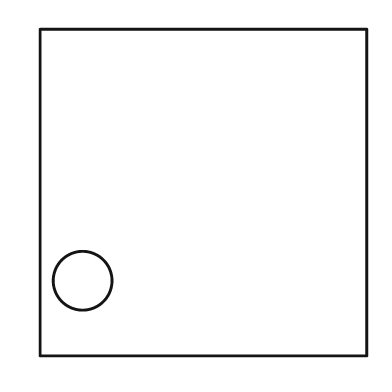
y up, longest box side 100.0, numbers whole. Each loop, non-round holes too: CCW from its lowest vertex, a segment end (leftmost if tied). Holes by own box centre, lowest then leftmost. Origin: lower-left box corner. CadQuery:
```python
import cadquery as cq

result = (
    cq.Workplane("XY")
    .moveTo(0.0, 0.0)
    .lineTo(100.0, 0.0)
    .lineTo(100.0, 100.0)
    .lineTo(0.0, 100.0)
    .close()
    .moveTo(13.0, 23.0)
    .circle(9.0)
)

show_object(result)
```